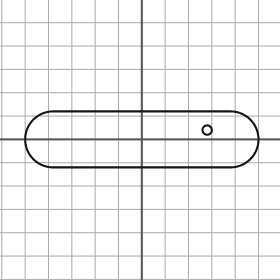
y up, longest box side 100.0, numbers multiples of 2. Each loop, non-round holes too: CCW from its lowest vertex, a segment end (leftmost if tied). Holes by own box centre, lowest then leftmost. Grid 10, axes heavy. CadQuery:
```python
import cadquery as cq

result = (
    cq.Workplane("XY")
    .moveTo(-38.0, -12.0)
    .lineTo(38.0, -12.0)
    .threePointArc((50.0, 0.0), (38.0, 12.0))
    .lineTo(-38.0, 12.0)
    .threePointArc((-50.0, 0.0), (-38.0, -12.0))
    .close()
    .moveTo(28.0, 4.0)
    .circle(2.0)
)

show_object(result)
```